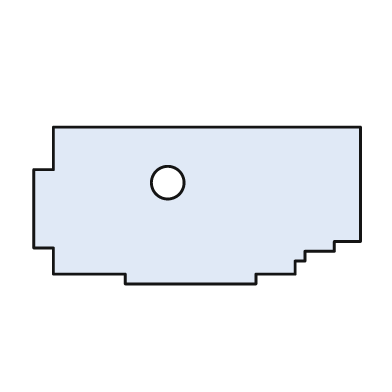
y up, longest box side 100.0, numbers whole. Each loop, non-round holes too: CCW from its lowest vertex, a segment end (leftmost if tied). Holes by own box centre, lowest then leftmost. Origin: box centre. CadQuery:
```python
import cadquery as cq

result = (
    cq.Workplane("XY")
    .moveTo(-22.0, -24.0)
    .lineTo(18.0, -24.0)
    .lineTo(18.0, -21.0)
    .lineTo(30.0, -21.0)
    .lineTo(30.0, -17.0)
    .lineTo(33.0, -17.0)
    .lineTo(33.0, -14.0)
    .lineTo(42.0, -14.0)
    .lineTo(42.0, -11.0)
    .lineTo(50.0, -11.0)
    .lineTo(50.0, 24.0)
    .lineTo(-44.0, 24.0)
    .lineTo(-44.0, 11.0)
    .lineTo(-50.0, 11.0)
    .lineTo(-50.0, -13.0)
    .lineTo(-44.0, -13.0)
    .lineTo(-44.0, -21.0)
    .lineTo(-22.0, -21.0)
    .close()
    .moveTo(-9.0, 7.0)
    .circle(5.0)
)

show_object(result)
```